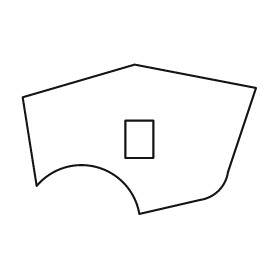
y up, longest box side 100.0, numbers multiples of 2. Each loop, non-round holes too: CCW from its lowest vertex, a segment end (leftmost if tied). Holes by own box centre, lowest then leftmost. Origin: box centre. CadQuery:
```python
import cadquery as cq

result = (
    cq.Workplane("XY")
    .moveTo(0.0, -32.0)
    .lineTo(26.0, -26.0)
    .threePointArc((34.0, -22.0), (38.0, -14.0))
    .lineTo(50.0, 22.0)
    .lineTo(-2.0, 32.0)
    .lineTo(-50.0, 18.0)
    .lineTo(-44.0, -20.0)
    .threePointArc((-18.0, -12.0), (0.0, -32.0))
    .close()
    .moveTo(-6.0, -8.0)
    .lineTo(6.0, -8.0)
    .lineTo(6.0, 8.0)
    .lineTo(-6.0, 8.0)
    .close()
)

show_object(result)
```